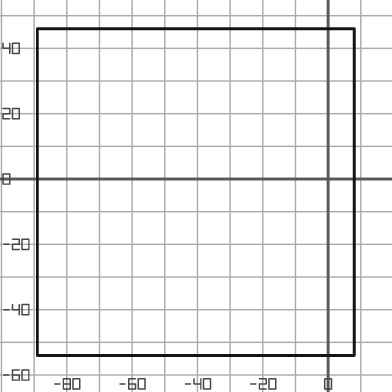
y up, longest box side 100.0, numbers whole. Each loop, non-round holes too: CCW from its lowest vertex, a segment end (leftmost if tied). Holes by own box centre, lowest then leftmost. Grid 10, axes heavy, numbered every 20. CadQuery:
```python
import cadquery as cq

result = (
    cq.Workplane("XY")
    .moveTo(-89.0, -54.0)
    .lineTo(8.0, -54.0)
    .lineTo(8.0, 46.0)
    .lineTo(-89.0, 46.0)
    .close()
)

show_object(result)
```